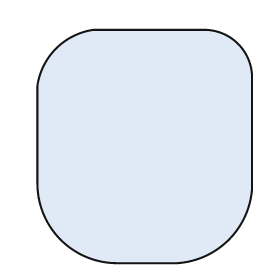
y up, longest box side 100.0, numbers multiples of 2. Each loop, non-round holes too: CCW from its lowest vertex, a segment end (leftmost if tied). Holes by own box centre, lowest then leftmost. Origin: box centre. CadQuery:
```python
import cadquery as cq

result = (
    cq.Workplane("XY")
    .moveTo(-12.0, -50.0)
    .lineTo(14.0, -50.0)
    .threePointArc((36.0, -40.0), (46.0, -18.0))
    .lineTo(46.0, 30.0)
    .threePointArc((40.0, 44.0), (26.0, 50.0))
    .lineTo(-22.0, 50.0)
    .threePointArc((-38.0, 42.0), (-46.0, 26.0))
    .lineTo(-46.0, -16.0)
    .threePointArc((-36.0, -40.0), (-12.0, -50.0))
    .close()
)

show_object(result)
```